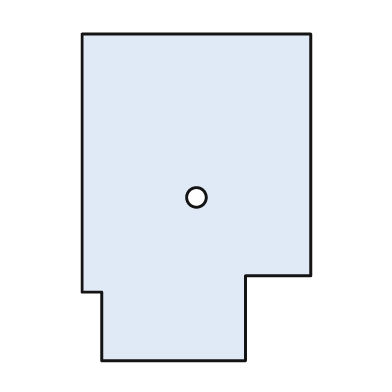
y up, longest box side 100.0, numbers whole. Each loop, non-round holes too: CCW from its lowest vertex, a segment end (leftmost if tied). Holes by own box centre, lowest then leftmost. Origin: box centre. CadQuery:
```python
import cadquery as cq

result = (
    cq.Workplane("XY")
    .moveTo(-29.0, -50.0)
    .lineTo(15.0, -50.0)
    .lineTo(15.0, -24.0)
    .lineTo(35.0, -24.0)
    .lineTo(35.0, 50.0)
    .lineTo(-35.0, 50.0)
    .lineTo(-35.0, -29.0)
    .lineTo(-29.0, -29.0)
    .close()
    .moveTo(0.0, 0.0)
    .circle(3.0)
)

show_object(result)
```